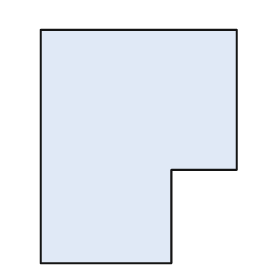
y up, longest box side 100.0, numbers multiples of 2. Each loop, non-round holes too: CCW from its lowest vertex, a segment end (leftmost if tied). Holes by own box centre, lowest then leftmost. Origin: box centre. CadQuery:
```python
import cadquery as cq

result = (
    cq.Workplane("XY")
    .moveTo(-42.0, -50.0)
    .lineTo(14.0, -50.0)
    .lineTo(14.0, -10.0)
    .lineTo(42.0, -10.0)
    .lineTo(42.0, 50.0)
    .lineTo(-42.0, 50.0)
    .close()
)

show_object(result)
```